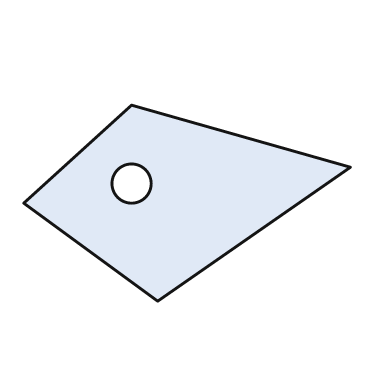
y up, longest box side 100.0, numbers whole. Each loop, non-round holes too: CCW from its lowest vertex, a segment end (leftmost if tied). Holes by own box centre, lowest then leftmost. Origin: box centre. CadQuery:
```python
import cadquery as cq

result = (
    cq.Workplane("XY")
    .moveTo(-9.0, -30.0)
    .lineTo(50.0, 11.0)
    .lineTo(-17.0, 30.0)
    .lineTo(-50.0, 0.0)
    .close()
    .moveTo(-17.0, 6.0)
    .circle(6.0)
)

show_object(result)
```